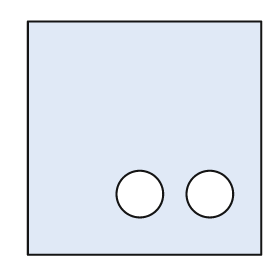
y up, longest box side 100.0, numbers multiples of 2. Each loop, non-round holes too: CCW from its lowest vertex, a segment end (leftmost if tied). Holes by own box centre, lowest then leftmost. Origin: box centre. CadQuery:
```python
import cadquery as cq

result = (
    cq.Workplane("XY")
    .moveTo(-50.0, -50.0)
    .lineTo(50.0, -50.0)
    .lineTo(50.0, 50.0)
    .lineTo(-50.0, 50.0)
    .close()
    .moveTo(-2.0, -24.0)
    .circle(10.0)
    .moveTo(28.0, -24.0)
    .circle(10.0)
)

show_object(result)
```